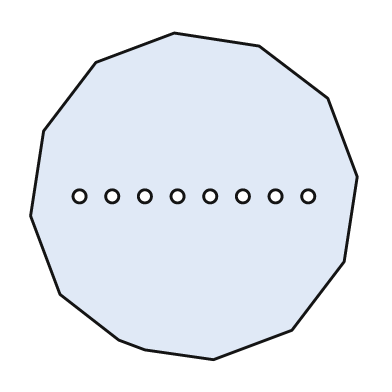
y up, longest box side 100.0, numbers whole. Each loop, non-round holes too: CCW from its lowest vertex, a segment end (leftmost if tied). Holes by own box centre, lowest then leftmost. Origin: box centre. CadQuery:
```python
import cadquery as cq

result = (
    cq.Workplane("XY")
    .moveTo(6.0, -50.0)
    .lineTo(30.0, -41.0)
    .lineTo(46.0, -20.0)
    .lineTo(50.0, 6.0)
    .lineTo(41.0, 30.0)
    .lineTo(20.0, 46.0)
    .lineTo(-6.0, 50.0)
    .lineTo(-30.0, 41.0)
    .lineTo(-46.0, 20.0)
    .lineTo(-50.0, -6.0)
    .lineTo(-41.0, -30.0)
    .lineTo(-23.0, -44.0)
    .lineTo(-15.0, -47.0)
    .close()
    .moveTo(-35.0, 0.0)
    .circle(2.0)
    .moveTo(-25.0, 0.0)
    .circle(2.0)
    .moveTo(-15.0, 0.0)
    .circle(2.0)
    .moveTo(-5.0, 0.0)
    .circle(2.0)
    .moveTo(5.0, 0.0)
    .circle(2.0)
    .moveTo(15.0, 0.0)
    .circle(2.0)
    .moveTo(25.0, 0.0)
    .circle(2.0)
    .moveTo(35.0, 0.0)
    .circle(2.0)
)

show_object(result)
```